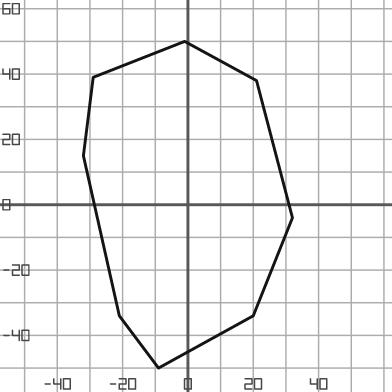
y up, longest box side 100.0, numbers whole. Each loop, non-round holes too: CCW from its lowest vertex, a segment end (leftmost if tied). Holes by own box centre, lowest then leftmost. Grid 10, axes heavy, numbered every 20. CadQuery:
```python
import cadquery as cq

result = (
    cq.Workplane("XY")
    .moveTo(-9.0, -50.0)
    .lineTo(20.0, -34.0)
    .lineTo(32.0, -4.0)
    .lineTo(21.0, 38.0)
    .lineTo(-1.0, 50.0)
    .lineTo(-29.0, 39.0)
    .lineTo(-32.0, 15.0)
    .lineTo(-21.0, -34.0)
    .close()
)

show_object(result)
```